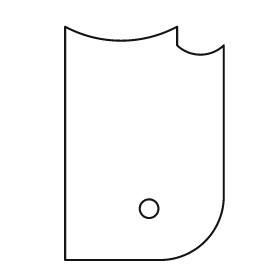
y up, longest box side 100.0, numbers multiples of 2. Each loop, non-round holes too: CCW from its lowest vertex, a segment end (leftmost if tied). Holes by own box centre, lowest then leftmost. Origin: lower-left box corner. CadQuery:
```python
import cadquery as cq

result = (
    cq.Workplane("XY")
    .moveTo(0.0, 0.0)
    .lineTo(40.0, 0.0)
    .threePointArc((60.0, 8.0), (68.0, 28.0))
    .lineTo(68.0, 92.0)
    .threePointArc((58.0, 88.0), (48.0, 92.0))
    .lineTo(48.0, 100.0)
    .threePointArc((24.0, 94.0), (0.0, 100.0))
    .close()
    .moveTo(36.0, 22.0)
    .circle(4.0)
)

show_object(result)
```